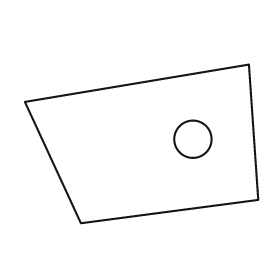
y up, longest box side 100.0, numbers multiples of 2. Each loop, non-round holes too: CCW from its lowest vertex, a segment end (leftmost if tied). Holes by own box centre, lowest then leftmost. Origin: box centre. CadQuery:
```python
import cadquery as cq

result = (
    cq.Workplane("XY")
    .moveTo(-26.0, -34.0)
    .lineTo(50.0, -24.0)
    .lineTo(46.0, 34.0)
    .lineTo(-50.0, 18.0)
    .close()
    .moveTo(22.0, 2.0)
    .circle(8.0)
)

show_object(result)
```